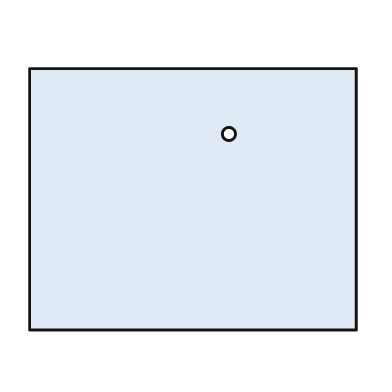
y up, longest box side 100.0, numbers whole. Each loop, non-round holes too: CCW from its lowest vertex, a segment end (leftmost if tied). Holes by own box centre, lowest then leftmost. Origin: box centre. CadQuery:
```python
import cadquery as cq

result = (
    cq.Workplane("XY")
    .moveTo(-50.0, -40.0)
    .lineTo(50.0, -40.0)
    .lineTo(50.0, 40.0)
    .lineTo(-50.0, 40.0)
    .close()
    .moveTo(11.0, 20.0)
    .circle(2.0)
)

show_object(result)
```